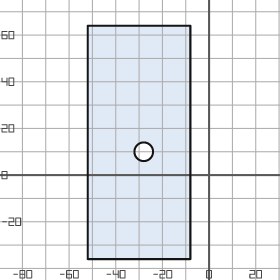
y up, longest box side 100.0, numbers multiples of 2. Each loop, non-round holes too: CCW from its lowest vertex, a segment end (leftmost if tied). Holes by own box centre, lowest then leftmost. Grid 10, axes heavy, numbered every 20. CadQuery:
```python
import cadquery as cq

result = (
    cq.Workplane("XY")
    .moveTo(-52.0, -36.0)
    .lineTo(-8.0, -36.0)
    .lineTo(-8.0, 64.0)
    .lineTo(-52.0, 64.0)
    .close()
    .moveTo(-28.0, 10.0)
    .circle(4.0)
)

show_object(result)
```